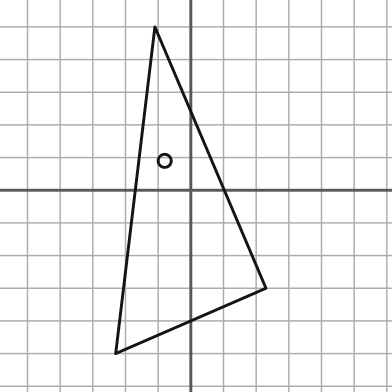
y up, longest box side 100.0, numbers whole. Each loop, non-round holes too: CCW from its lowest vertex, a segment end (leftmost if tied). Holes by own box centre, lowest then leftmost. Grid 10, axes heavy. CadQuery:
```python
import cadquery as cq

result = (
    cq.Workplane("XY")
    .moveTo(-23.0, -50.0)
    .lineTo(23.0, -30.0)
    .lineTo(-11.0, 50.0)
    .close()
    .moveTo(-8.0, 9.0)
    .circle(2.0)
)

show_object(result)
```